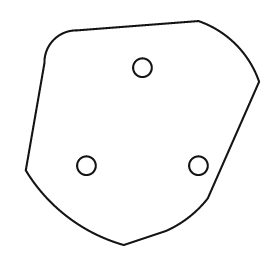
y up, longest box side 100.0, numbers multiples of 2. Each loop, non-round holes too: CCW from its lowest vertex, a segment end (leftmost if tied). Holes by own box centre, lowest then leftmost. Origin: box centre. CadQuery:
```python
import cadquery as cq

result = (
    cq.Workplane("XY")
    .moveTo(-8.0, -48.0)
    .lineTo(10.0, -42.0)
    .threePointArc((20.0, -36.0), (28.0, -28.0))
    .lineTo(50.0, 22.0)
    .threePointArc((40.0, 38.0), (24.0, 48.0))
    .lineTo(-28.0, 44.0)
    .threePointArc((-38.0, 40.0), (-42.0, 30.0))
    .lineTo(-50.0, -16.0)
    .threePointArc((-32.0, -36.0), (-8.0, -48.0))
    .close()
    .moveTo(-24.0, -14.0)
    .circle(4.0)
    .moveTo(24.0, -14.0)
    .circle(4.0)
    .moveTo(0.0, 28.0)
    .circle(4.0)
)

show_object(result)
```